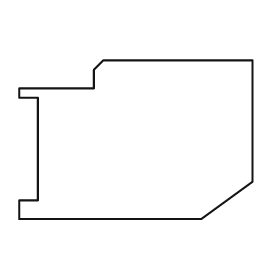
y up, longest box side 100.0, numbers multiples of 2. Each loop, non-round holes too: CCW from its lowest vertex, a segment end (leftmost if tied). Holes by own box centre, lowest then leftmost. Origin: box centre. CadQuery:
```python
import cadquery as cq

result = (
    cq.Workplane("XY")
    .moveTo(-50.0, -34.0)
    .lineTo(28.0, -34.0)
    .lineTo(50.0, -18.0)
    .lineTo(50.0, 34.0)
    .lineTo(-14.0, 34.0)
    .lineTo(-18.0, 30.0)
    .lineTo(-18.0, 22.0)
    .lineTo(-50.0, 22.0)
    .lineTo(-50.0, 18.0)
    .lineTo(-42.0, 18.0)
    .lineTo(-42.0, -26.0)
    .lineTo(-50.0, -26.0)
    .close()
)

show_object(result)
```